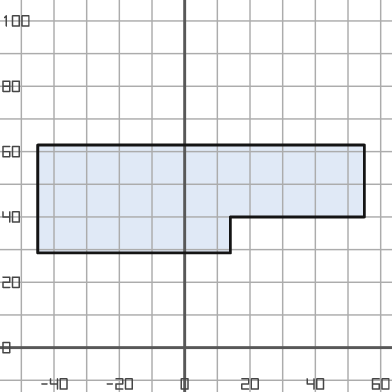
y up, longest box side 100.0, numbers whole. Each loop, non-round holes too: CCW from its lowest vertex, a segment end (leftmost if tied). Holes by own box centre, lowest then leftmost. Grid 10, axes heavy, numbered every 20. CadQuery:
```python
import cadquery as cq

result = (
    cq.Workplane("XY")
    .moveTo(-45.0, 29.0)
    .lineTo(14.0, 29.0)
    .lineTo(14.0, 40.0)
    .lineTo(55.0, 40.0)
    .lineTo(55.0, 62.0)
    .lineTo(-45.0, 62.0)
    .close()
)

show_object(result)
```